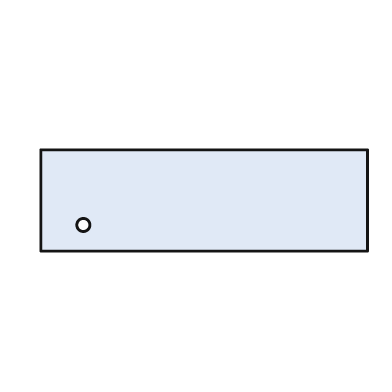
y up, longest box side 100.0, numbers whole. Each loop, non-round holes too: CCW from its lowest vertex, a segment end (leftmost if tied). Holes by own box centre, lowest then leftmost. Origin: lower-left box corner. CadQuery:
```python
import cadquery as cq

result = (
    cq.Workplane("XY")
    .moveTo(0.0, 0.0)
    .lineTo(100.0, 0.0)
    .lineTo(100.0, 31.0)
    .lineTo(0.0, 31.0)
    .close()
    .moveTo(13.0, 8.0)
    .circle(2.0)
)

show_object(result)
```